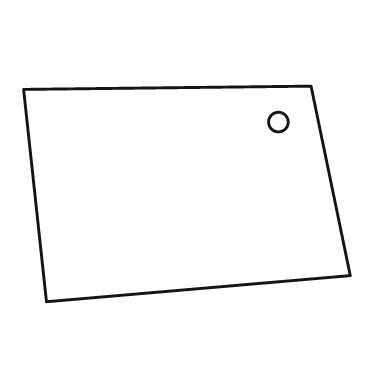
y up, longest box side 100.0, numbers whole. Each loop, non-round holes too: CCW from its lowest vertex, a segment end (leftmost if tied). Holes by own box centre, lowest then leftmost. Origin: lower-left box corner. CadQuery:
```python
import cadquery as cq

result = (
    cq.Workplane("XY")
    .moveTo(7.0, 0.0)
    .lineTo(100.0, 8.0)
    .lineTo(88.0, 66.0)
    .lineTo(0.0, 65.0)
    .close()
    .moveTo(78.0, 55.0)
    .circle(3.0)
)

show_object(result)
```